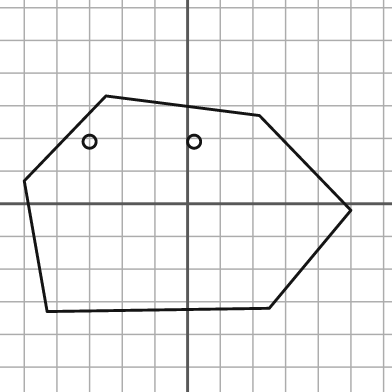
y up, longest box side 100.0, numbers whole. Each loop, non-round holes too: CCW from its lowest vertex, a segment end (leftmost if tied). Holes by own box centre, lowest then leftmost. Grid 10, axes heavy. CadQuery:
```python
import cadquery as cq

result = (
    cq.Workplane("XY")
    .moveTo(-43.0, -33.0)
    .lineTo(25.0, -32.0)
    .lineTo(50.0, -2.0)
    .lineTo(22.0, 27.0)
    .lineTo(-25.0, 33.0)
    .lineTo(-50.0, 7.0)
    .close()
    .moveTo(-30.0, 19.0)
    .circle(2.0)
    .moveTo(2.0, 19.0)
    .circle(2.0)
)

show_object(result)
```